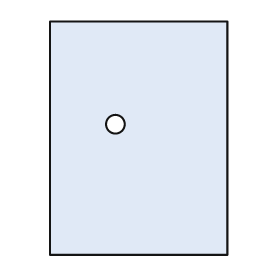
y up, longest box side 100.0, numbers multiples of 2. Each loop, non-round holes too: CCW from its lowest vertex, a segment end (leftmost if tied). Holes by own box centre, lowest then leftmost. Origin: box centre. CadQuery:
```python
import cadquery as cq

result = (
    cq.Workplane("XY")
    .moveTo(-38.0, -50.0)
    .lineTo(38.0, -50.0)
    .lineTo(38.0, 50.0)
    .lineTo(-38.0, 50.0)
    .close()
    .moveTo(-10.0, 6.0)
    .circle(4.0)
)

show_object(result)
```